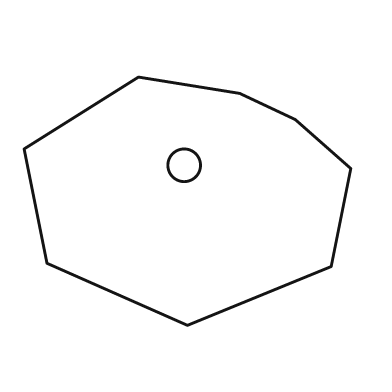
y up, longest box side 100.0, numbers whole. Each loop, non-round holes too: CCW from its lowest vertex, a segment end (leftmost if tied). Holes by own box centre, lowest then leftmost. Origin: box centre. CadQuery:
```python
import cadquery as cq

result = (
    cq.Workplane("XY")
    .moveTo(0.0, -38.0)
    .lineTo(44.0, -20.0)
    .lineTo(50.0, 10.0)
    .lineTo(33.0, 25.0)
    .lineTo(16.0, 33.0)
    .lineTo(-15.0, 38.0)
    .lineTo(-50.0, 16.0)
    .lineTo(-43.0, -19.0)
    .close()
    .moveTo(-1.0, 11.0)
    .circle(5.0)
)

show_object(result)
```